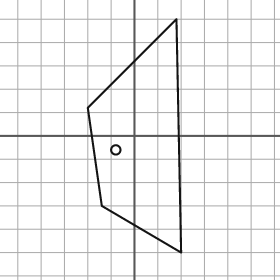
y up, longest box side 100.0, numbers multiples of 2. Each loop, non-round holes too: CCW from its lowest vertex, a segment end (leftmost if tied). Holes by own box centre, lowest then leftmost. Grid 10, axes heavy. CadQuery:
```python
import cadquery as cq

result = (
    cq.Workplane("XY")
    .moveTo(20.0, -50.0)
    .lineTo(18.0, 50.0)
    .lineTo(-20.0, 12.0)
    .lineTo(-14.0, -30.0)
    .close()
    .moveTo(-8.0, -6.0)
    .circle(2.0)
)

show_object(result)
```